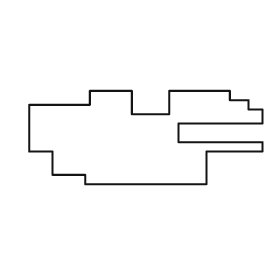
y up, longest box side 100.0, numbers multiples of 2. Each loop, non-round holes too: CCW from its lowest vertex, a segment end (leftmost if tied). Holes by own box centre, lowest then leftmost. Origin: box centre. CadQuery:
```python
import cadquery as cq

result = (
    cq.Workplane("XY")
    .moveTo(-26.0, -20.0)
    .lineTo(26.0, -20.0)
    .lineTo(26.0, -6.0)
    .lineTo(50.0, -6.0)
    .lineTo(50.0, -2.0)
    .lineTo(14.0, -2.0)
    .lineTo(14.0, 6.0)
    .lineTo(50.0, 6.0)
    .lineTo(50.0, 12.0)
    .lineTo(44.0, 12.0)
    .lineTo(44.0, 16.0)
    .lineTo(36.0, 16.0)
    .lineTo(36.0, 20.0)
    .lineTo(10.0, 20.0)
    .lineTo(10.0, 10.0)
    .lineTo(-6.0, 10.0)
    .lineTo(-6.0, 20.0)
    .lineTo(-24.0, 20.0)
    .lineTo(-24.0, 14.0)
    .lineTo(-50.0, 14.0)
    .lineTo(-50.0, -6.0)
    .lineTo(-40.0, -6.0)
    .lineTo(-40.0, -16.0)
    .lineTo(-26.0, -16.0)
    .close()
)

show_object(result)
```